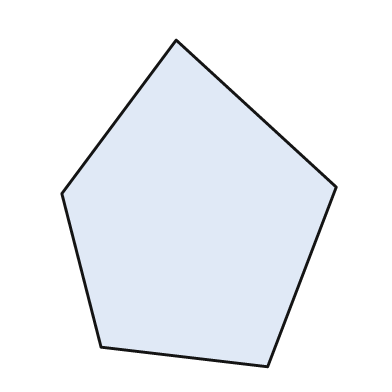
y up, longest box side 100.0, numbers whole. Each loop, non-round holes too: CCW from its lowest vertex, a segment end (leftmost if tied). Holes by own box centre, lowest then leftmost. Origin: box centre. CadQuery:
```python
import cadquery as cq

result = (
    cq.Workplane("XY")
    .moveTo(21.0, -50.0)
    .lineTo(42.0, 5.0)
    .lineTo(-7.0, 50.0)
    .lineTo(-42.0, 3.0)
    .lineTo(-30.0, -44.0)
    .close()
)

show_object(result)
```